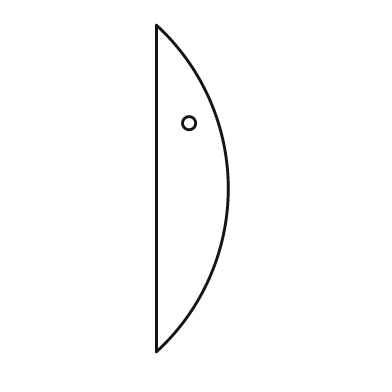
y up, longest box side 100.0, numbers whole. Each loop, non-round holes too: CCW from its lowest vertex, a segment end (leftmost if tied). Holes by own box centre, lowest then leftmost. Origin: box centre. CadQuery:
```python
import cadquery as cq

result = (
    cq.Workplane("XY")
    .moveTo(-11.0, -50.0)
    .threePointArc((11.0, 0.0), (-11.0, 50.0))
    .close()
    .moveTo(-1.0, 20.0)
    .circle(2.0)
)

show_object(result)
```